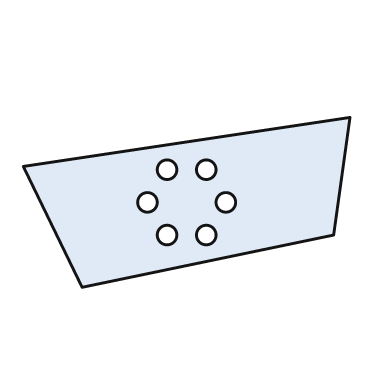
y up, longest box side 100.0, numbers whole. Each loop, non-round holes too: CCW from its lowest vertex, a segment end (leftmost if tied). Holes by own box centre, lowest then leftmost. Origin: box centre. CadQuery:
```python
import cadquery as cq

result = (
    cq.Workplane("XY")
    .moveTo(-32.0, -26.0)
    .lineTo(45.0, -10.0)
    .lineTo(50.0, 26.0)
    .lineTo(-50.0, 11.0)
    .close()
    .moveTo(-6.0, -10.0)
    .circle(3.0)
    .moveTo(6.0, -10.0)
    .circle(3.0)
    .moveTo(-12.0, 0.0)
    .circle(3.0)
    .moveTo(12.0, 0.0)
    .circle(3.0)
    .moveTo(-6.0, 10.0)
    .circle(3.0)
    .moveTo(6.0, 10.0)
    .circle(3.0)
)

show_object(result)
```